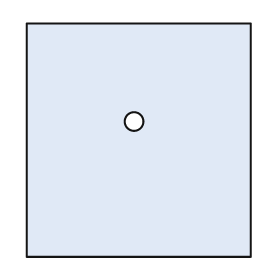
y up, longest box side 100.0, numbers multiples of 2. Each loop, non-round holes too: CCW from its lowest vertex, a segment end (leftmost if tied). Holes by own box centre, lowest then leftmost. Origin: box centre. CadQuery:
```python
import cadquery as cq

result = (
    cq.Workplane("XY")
    .moveTo(-48.0, -50.0)
    .lineTo(48.0, -50.0)
    .lineTo(48.0, 50.0)
    .lineTo(-48.0, 50.0)
    .close()
    .moveTo(-2.0, 8.0)
    .circle(4.0)
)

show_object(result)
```